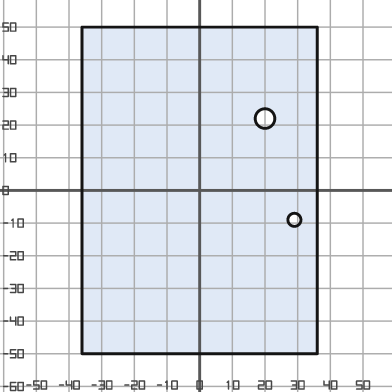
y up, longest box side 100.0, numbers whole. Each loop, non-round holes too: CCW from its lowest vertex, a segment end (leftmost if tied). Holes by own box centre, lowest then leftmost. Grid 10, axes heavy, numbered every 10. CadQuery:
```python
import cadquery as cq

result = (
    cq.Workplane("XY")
    .moveTo(-36.0, -50.0)
    .lineTo(36.0, -50.0)
    .lineTo(36.0, 50.0)
    .lineTo(-36.0, 50.0)
    .close()
    .moveTo(29.0, -9.0)
    .circle(2.0)
    .moveTo(20.0, 22.0)
    .circle(3.0)
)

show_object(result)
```